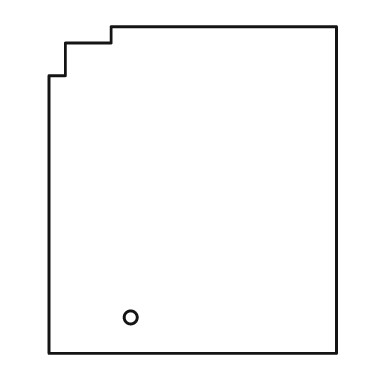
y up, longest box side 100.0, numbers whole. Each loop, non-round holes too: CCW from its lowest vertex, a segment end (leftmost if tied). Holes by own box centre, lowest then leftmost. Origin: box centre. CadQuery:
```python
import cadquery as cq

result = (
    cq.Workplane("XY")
    .moveTo(-44.0, -50.0)
    .lineTo(44.0, -50.0)
    .lineTo(44.0, 50.0)
    .lineTo(-25.0, 50.0)
    .lineTo(-25.0, 45.0)
    .lineTo(-39.0, 45.0)
    .lineTo(-39.0, 35.0)
    .lineTo(-44.0, 35.0)
    .close()
    .moveTo(-19.0, -39.0)
    .circle(2.0)
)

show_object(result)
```